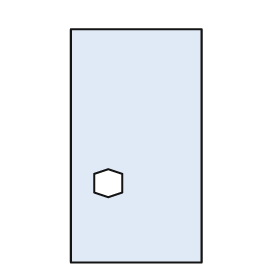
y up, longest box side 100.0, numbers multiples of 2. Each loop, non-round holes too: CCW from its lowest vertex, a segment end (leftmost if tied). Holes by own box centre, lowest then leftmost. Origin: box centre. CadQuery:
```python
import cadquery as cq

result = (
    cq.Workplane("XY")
    .moveTo(-28.0, -50.0)
    .lineTo(28.0, -50.0)
    .lineTo(28.0, 50.0)
    .lineTo(-28.0, 50.0)
    .close()
    .moveTo(-12.0, -22.0)
    .lineTo(-6.0, -20.0)
    .lineTo(-6.0, -12.0)
    .lineTo(-12.0, -10.0)
    .lineTo(-18.0, -12.0)
    .lineTo(-18.0, -20.0)
    .close()
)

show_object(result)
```